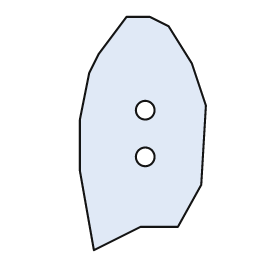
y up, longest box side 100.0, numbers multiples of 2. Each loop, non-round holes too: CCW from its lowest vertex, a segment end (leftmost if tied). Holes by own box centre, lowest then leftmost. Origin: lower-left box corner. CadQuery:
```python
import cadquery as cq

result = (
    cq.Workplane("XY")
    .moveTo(6.0, 0.0)
    .lineTo(26.0, 10.0)
    .lineTo(42.0, 10.0)
    .lineTo(52.0, 28.0)
    .lineTo(54.0, 62.0)
    .lineTo(48.0, 80.0)
    .lineTo(38.0, 96.0)
    .lineTo(30.0, 100.0)
    .lineTo(20.0, 100.0)
    .lineTo(8.0, 84.0)
    .lineTo(4.0, 76.0)
    .lineTo(0.0, 56.0)
    .lineTo(0.0, 34.0)
    .close()
    .moveTo(28.0, 40.0)
    .circle(4.0)
    .moveTo(28.0, 60.0)
    .circle(4.0)
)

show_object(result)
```